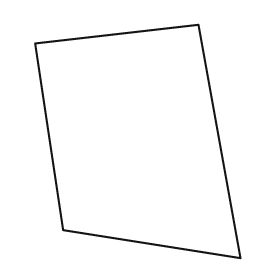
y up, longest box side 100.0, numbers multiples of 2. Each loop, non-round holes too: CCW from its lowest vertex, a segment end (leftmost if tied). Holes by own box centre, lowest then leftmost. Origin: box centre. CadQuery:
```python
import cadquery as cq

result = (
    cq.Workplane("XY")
    .moveTo(44.0, -50.0)
    .lineTo(26.0, 50.0)
    .lineTo(-44.0, 42.0)
    .lineTo(-32.0, -38.0)
    .close()
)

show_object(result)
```